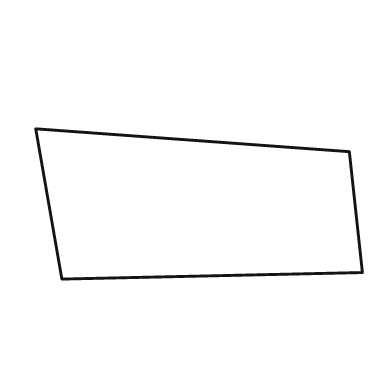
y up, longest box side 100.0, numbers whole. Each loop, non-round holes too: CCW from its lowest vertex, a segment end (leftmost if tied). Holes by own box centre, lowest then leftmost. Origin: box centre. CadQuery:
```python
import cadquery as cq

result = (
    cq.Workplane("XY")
    .moveTo(-42.0, -23.0)
    .lineTo(50.0, -21.0)
    .lineTo(46.0, 16.0)
    .lineTo(-50.0, 23.0)
    .close()
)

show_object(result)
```